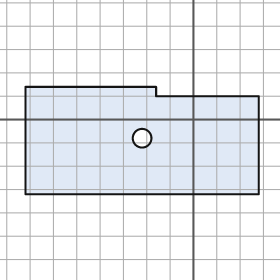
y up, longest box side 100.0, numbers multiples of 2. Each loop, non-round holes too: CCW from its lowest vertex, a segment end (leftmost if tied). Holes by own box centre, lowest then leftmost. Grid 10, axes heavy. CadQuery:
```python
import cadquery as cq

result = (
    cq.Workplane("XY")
    .moveTo(-72.0, -32.0)
    .lineTo(28.0, -32.0)
    .lineTo(28.0, 10.0)
    .lineTo(-16.0, 10.0)
    .lineTo(-16.0, 14.0)
    .lineTo(-72.0, 14.0)
    .close()
    .moveTo(-22.0, -8.0)
    .circle(4.0)
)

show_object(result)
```